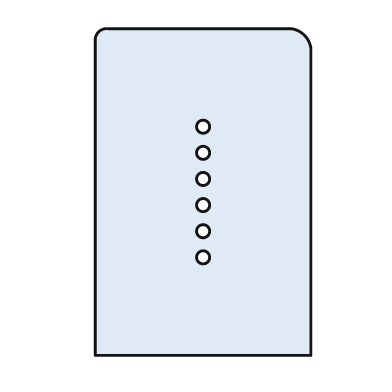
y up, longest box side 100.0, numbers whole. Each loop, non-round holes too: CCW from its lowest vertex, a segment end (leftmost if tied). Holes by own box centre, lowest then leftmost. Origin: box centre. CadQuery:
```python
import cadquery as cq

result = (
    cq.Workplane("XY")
    .moveTo(-33.0, -50.0)
    .lineTo(33.0, -50.0)
    .lineTo(33.0, 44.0)
    .threePointArc((31.0, 48.0), (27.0, 50.0))
    .lineTo(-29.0, 50.0)
    .threePointArc((-32.0, 49.0), (-33.0, 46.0))
    .close()
    .moveTo(0.0, -20.0)
    .circle(2.0)
    .moveTo(0.0, -12.0)
    .circle(2.0)
    .moveTo(0.0, -4.0)
    .circle(2.0)
    .moveTo(0.0, 4.0)
    .circle(2.0)
    .moveTo(0.0, 12.0)
    .circle(2.0)
    .moveTo(0.0, 20.0)
    .circle(2.0)
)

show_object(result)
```